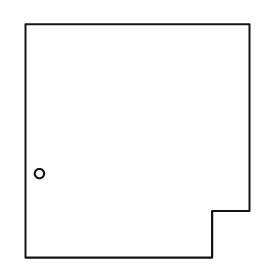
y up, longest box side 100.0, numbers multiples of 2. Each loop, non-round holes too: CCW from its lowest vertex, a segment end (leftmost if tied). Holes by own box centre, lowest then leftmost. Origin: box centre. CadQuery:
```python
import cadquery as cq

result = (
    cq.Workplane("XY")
    .moveTo(-48.0, -50.0)
    .lineTo(32.0, -50.0)
    .lineTo(32.0, -30.0)
    .lineTo(48.0, -30.0)
    .lineTo(48.0, 50.0)
    .lineTo(-48.0, 50.0)
    .close()
    .moveTo(-42.0, -14.0)
    .circle(2.0)
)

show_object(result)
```